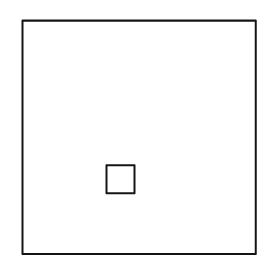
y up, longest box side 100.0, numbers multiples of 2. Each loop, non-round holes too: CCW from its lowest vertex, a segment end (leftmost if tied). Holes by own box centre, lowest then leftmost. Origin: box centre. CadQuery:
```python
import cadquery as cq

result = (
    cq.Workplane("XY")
    .moveTo(-50.0, -50.0)
    .lineTo(50.0, -50.0)
    .lineTo(50.0, 50.0)
    .lineTo(-50.0, 50.0)
    .close()
    .moveTo(-14.0, -24.0)
    .lineTo(-2.0, -24.0)
    .lineTo(-2.0, -12.0)
    .lineTo(-14.0, -12.0)
    .close()
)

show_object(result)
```